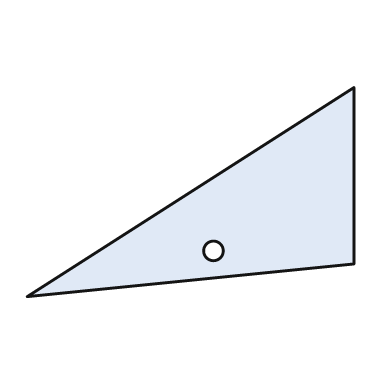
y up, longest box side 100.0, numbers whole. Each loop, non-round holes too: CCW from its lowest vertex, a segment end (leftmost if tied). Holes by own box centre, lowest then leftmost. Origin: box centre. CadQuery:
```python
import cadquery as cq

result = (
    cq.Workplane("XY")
    .moveTo(-50.0, -32.0)
    .lineTo(50.0, -22.0)
    .lineTo(50.0, 32.0)
    .close()
    .moveTo(7.0, -18.0)
    .circle(3.0)
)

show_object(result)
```